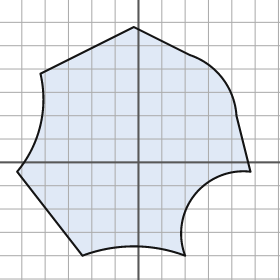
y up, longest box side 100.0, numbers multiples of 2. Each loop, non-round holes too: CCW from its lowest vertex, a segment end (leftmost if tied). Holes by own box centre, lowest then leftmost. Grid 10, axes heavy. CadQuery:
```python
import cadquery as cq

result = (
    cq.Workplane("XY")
    .moveTo(-24.0, -40.0)
    .threePointArc((-2.0, -36.0), (20.0, -40.0))
    .threePointArc((24.0, -14.0), (48.0, -4.0))
    .lineTo(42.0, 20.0)
    .threePointArc((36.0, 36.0), (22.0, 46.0))
    .lineTo(-2.0, 58.0)
    .lineTo(-42.0, 38.0)
    .threePointArc((-42.0, 16.0), (-52.0, -4.0))
    .close()
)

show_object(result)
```